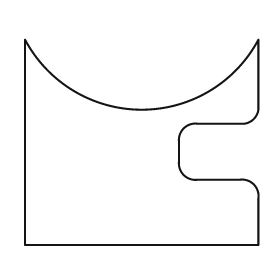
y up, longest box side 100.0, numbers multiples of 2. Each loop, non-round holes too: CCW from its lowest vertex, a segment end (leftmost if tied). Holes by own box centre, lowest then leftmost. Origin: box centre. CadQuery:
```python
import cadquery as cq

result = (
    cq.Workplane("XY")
    .moveTo(-50.0, -44.0)
    .lineTo(50.0, -44.0)
    .lineTo(50.0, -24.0)
    .threePointArc((48.0, -18.0), (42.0, -16.0))
    .lineTo(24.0, -16.0)
    .threePointArc((18.0, -14.0), (16.0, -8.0))
    .lineTo(16.0, 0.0)
    .threePointArc((18.0, 6.0), (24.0, 8.0))
    .lineTo(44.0, 8.0)
    .threePointArc((48.0, 10.0), (50.0, 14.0))
    .lineTo(50.0, 44.0)
    .threePointArc((0.0, 14.0), (-50.0, 44.0))
    .close()
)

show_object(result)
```